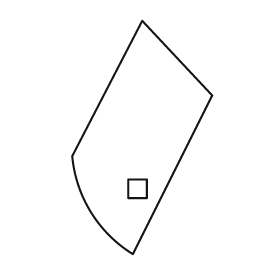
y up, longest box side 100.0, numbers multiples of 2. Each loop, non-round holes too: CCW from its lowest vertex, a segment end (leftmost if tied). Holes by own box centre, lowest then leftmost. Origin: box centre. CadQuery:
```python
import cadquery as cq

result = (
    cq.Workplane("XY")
    .moveTo(-4.0, -50.0)
    .lineTo(30.0, 18.0)
    .lineTo(0.0, 50.0)
    .lineTo(-30.0, -8.0)
    .threePointArc((-22.0, -32.0), (-4.0, -50.0))
    .close()
    .moveTo(-6.0, -26.0)
    .lineTo(2.0, -26.0)
    .lineTo(2.0, -18.0)
    .lineTo(-6.0, -18.0)
    .close()
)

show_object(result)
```